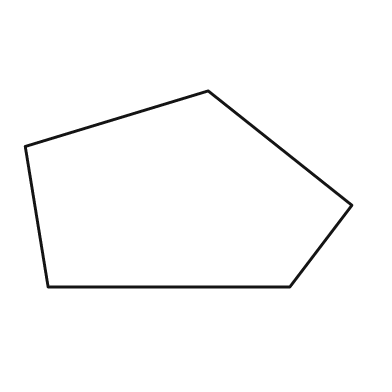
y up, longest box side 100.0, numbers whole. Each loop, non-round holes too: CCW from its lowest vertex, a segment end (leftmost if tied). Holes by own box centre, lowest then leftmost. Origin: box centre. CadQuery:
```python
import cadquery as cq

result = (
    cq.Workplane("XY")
    .moveTo(-43.0, -30.0)
    .lineTo(31.0, -30.0)
    .lineTo(50.0, -5.0)
    .lineTo(6.0, 30.0)
    .lineTo(-50.0, 13.0)
    .close()
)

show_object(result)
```